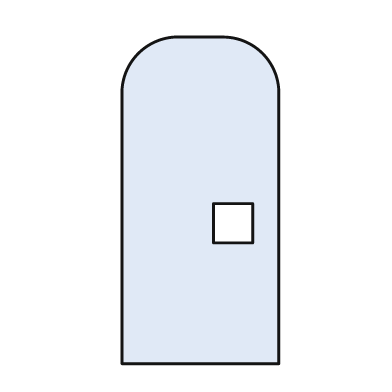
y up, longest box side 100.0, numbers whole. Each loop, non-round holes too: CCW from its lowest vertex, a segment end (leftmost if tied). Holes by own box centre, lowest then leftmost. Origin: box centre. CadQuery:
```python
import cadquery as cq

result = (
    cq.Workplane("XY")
    .moveTo(-24.0, -50.0)
    .lineTo(24.0, -50.0)
    .lineTo(24.0, 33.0)
    .threePointArc((19.0, 45.0), (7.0, 50.0))
    .lineTo(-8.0, 50.0)
    .threePointArc((-19.0, 45.0), (-24.0, 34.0))
    .close()
    .moveTo(4.0, -13.0)
    .lineTo(16.0, -13.0)
    .lineTo(16.0, -1.0)
    .lineTo(4.0, -1.0)
    .close()
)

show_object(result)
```